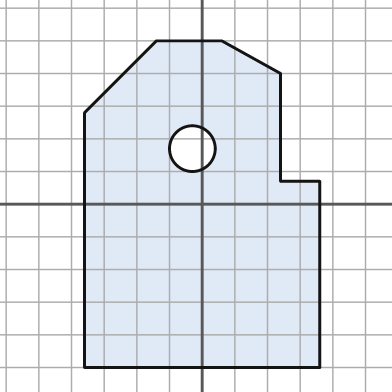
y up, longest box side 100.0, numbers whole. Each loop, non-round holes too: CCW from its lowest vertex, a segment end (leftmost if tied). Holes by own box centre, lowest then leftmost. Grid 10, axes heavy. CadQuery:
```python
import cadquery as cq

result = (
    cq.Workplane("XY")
    .moveTo(-36.0, -50.0)
    .lineTo(36.0, -50.0)
    .lineTo(36.0, 7.0)
    .lineTo(24.0, 7.0)
    .lineTo(24.0, 40.0)
    .lineTo(6.0, 50.0)
    .lineTo(-14.0, 50.0)
    .lineTo(-36.0, 28.0)
    .close()
    .moveTo(-3.0, 17.0)
    .circle(7.0)
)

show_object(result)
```